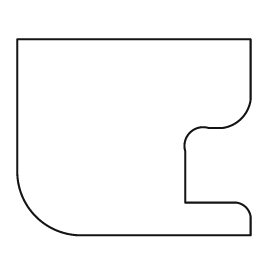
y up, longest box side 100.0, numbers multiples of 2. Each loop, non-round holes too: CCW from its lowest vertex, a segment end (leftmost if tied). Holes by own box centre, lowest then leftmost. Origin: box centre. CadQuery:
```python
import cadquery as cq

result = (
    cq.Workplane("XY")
    .moveTo(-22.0, -42.0)
    .lineTo(50.0, -42.0)
    .lineTo(50.0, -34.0)
    .threePointArc((48.0, -30.0), (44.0, -28.0))
    .lineTo(22.0, -28.0)
    .lineTo(22.0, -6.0)
    .threePointArc((24.0, 2.0), (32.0, 4.0))
    .lineTo(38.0, 4.0)
    .threePointArc((46.0, 8.0), (50.0, 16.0))
    .lineTo(50.0, 42.0)
    .lineTo(-50.0, 42.0)
    .lineTo(-50.0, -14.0)
    .threePointArc((-42.0, -34.0), (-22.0, -42.0))
    .close()
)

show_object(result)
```